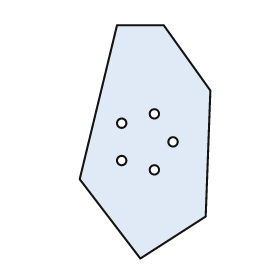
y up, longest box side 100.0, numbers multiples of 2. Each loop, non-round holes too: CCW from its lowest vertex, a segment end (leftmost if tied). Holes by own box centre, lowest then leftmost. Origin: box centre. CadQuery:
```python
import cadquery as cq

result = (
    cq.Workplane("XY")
    .moveTo(-2.0, -50.0)
    .lineTo(26.0, -32.0)
    .lineTo(28.0, 22.0)
    .lineTo(8.0, 50.0)
    .lineTo(-12.0, 50.0)
    .lineTo(-28.0, -16.0)
    .close()
    .moveTo(4.0, -12.0)
    .circle(2.0)
    .moveTo(-10.0, -8.0)
    .circle(2.0)
    .moveTo(12.0, 0.0)
    .circle(2.0)
    .moveTo(-10.0, 8.0)
    .circle(2.0)
    .moveTo(4.0, 12.0)
    .circle(2.0)
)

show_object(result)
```